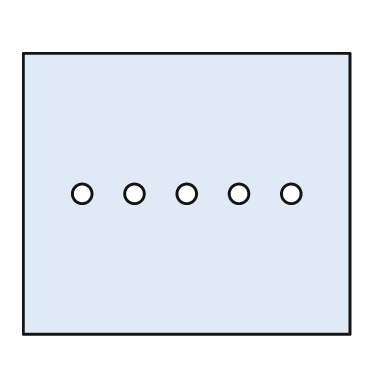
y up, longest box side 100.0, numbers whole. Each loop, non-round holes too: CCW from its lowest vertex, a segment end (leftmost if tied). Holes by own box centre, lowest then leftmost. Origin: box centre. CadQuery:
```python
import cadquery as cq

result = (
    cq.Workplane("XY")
    .moveTo(-50.0, -43.0)
    .lineTo(50.0, -43.0)
    .lineTo(50.0, 43.0)
    .lineTo(-50.0, 43.0)
    .close()
    .moveTo(-32.0, 0.0)
    .circle(3.0)
    .moveTo(-16.0, 0.0)
    .circle(3.0)
    .moveTo(0.0, 0.0)
    .circle(3.0)
    .moveTo(16.0, 0.0)
    .circle(3.0)
    .moveTo(32.0, 0.0)
    .circle(3.0)
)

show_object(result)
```